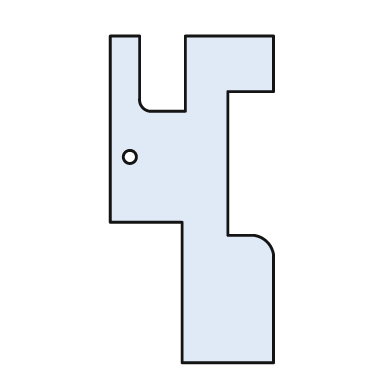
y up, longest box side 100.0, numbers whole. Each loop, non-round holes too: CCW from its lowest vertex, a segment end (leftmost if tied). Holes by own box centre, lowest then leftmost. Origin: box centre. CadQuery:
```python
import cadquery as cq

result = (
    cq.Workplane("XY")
    .moveTo(-3.0, -50.0)
    .lineTo(25.0, -50.0)
    .lineTo(25.0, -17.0)
    .threePointArc((23.0, -13.0), (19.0, -11.0))
    .lineTo(11.0, -11.0)
    .lineTo(11.0, 33.0)
    .lineTo(25.0, 33.0)
    .lineTo(25.0, 50.0)
    .lineTo(-2.0, 50.0)
    .lineTo(-2.0, 27.0)
    .lineTo(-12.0, 27.0)
    .threePointArc((-15.0, 28.0), (-16.0, 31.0))
    .lineTo(-16.0, 50.0)
    .lineTo(-25.0, 50.0)
    .lineTo(-25.0, -7.0)
    .lineTo(-3.0, -7.0)
    .close()
    .moveTo(-19.0, 13.0)
    .circle(2.0)
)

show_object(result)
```